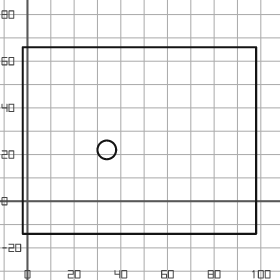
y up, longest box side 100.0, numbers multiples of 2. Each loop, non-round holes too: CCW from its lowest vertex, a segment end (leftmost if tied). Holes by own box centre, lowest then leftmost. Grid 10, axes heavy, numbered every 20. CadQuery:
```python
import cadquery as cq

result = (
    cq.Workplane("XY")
    .moveTo(-2.0, -14.0)
    .lineTo(98.0, -14.0)
    .lineTo(98.0, 66.0)
    .lineTo(-2.0, 66.0)
    .close()
    .moveTo(34.0, 22.0)
    .circle(4.0)
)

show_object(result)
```